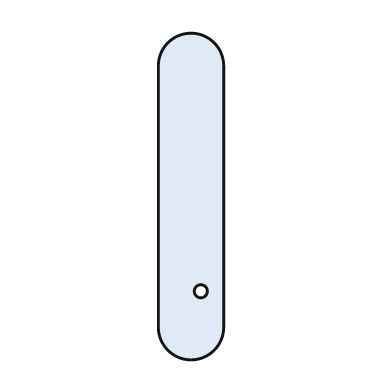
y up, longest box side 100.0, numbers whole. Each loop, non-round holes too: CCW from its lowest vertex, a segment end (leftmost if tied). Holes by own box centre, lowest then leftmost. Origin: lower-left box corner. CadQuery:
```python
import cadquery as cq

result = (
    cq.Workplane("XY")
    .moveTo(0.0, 10.0)
    .threePointArc((10.0, 0.0), (20.0, 10.0))
    .lineTo(20.0, 90.0)
    .threePointArc((10.0, 100.0), (0.0, 90.0))
    .close()
    .moveTo(13.0, 21.0)
    .circle(2.0)
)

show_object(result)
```